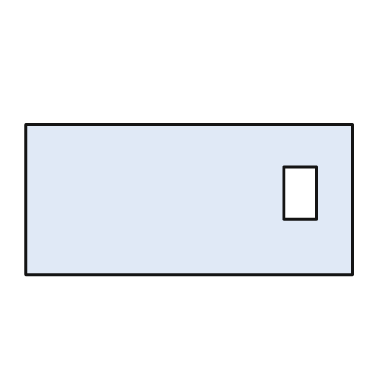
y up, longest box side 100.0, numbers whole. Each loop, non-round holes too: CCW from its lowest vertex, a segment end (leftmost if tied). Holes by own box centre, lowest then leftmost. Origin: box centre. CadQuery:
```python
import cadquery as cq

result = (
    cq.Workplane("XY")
    .moveTo(-50.0, -23.0)
    .lineTo(50.0, -23.0)
    .lineTo(50.0, 23.0)
    .lineTo(-50.0, 23.0)
    .close()
    .moveTo(29.0, -6.0)
    .lineTo(39.0, -6.0)
    .lineTo(39.0, 10.0)
    .lineTo(29.0, 10.0)
    .close()
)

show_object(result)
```